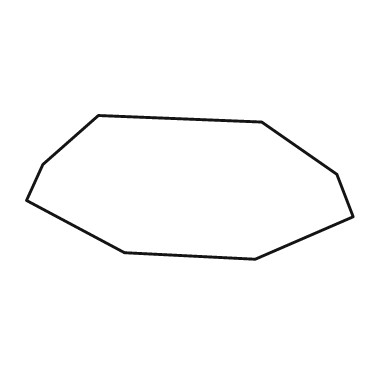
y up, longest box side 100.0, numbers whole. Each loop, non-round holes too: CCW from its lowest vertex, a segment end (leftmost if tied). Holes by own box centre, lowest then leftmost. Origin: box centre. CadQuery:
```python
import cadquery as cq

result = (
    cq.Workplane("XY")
    .moveTo(20.0, -22.0)
    .lineTo(50.0, -9.0)
    .lineTo(45.0, 4.0)
    .lineTo(22.0, 20.0)
    .lineTo(-28.0, 22.0)
    .lineTo(-45.0, 7.0)
    .lineTo(-50.0, -4.0)
    .lineTo(-20.0, -20.0)
    .close()
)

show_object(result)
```